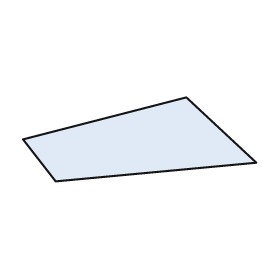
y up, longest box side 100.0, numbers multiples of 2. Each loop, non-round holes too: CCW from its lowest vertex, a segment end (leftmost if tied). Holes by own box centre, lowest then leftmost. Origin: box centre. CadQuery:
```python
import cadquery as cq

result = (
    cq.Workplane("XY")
    .moveTo(-36.0, -18.0)
    .lineTo(50.0, -10.0)
    .lineTo(20.0, 18.0)
    .lineTo(-50.0, 0.0)
    .close()
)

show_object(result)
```